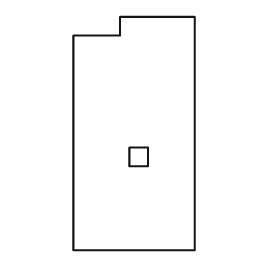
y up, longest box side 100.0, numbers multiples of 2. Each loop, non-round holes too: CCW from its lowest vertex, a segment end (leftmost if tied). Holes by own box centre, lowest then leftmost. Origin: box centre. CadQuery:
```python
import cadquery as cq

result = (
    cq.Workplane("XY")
    .moveTo(-26.0, -50.0)
    .lineTo(26.0, -50.0)
    .lineTo(26.0, 50.0)
    .lineTo(-6.0, 50.0)
    .lineTo(-6.0, 42.0)
    .lineTo(-26.0, 42.0)
    .close()
    .moveTo(-2.0, -14.0)
    .lineTo(6.0, -14.0)
    .lineTo(6.0, -6.0)
    .lineTo(-2.0, -6.0)
    .close()
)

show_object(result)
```